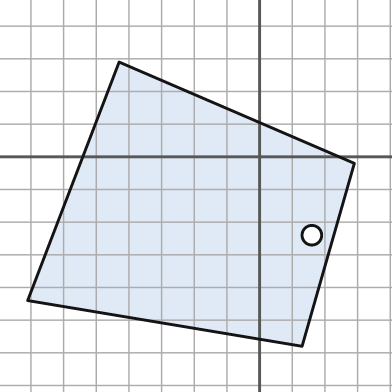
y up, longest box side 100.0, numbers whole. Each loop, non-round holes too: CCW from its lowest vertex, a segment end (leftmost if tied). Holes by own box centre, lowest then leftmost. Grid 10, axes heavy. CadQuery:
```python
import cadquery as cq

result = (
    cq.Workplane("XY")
    .moveTo(13.0, -58.0)
    .lineTo(29.0, -2.0)
    .lineTo(-43.0, 29.0)
    .lineTo(-71.0, -44.0)
    .close()
    .moveTo(16.0, -24.0)
    .circle(3.0)
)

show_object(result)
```